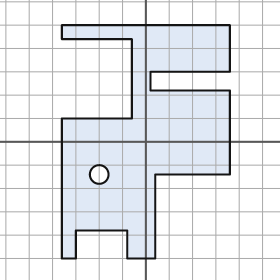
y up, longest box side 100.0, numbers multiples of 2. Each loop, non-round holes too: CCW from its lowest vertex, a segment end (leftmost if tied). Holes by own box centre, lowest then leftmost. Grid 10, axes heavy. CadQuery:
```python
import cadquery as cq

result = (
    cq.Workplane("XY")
    .moveTo(-36.0, -50.0)
    .lineTo(-30.0, -50.0)
    .lineTo(-30.0, -38.0)
    .lineTo(-8.0, -38.0)
    .lineTo(-8.0, -50.0)
    .lineTo(4.0, -50.0)
    .lineTo(4.0, -14.0)
    .lineTo(36.0, -14.0)
    .lineTo(36.0, 22.0)
    .lineTo(2.0, 22.0)
    .lineTo(2.0, 30.0)
    .lineTo(36.0, 30.0)
    .lineTo(36.0, 50.0)
    .lineTo(-36.0, 50.0)
    .lineTo(-36.0, 44.0)
    .lineTo(-6.0, 44.0)
    .lineTo(-6.0, 10.0)
    .lineTo(-36.0, 10.0)
    .close()
    .moveTo(-20.0, -14.0)
    .circle(4.0)
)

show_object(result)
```